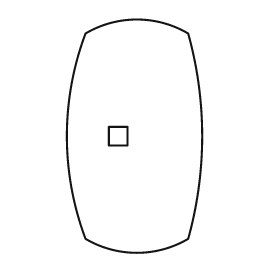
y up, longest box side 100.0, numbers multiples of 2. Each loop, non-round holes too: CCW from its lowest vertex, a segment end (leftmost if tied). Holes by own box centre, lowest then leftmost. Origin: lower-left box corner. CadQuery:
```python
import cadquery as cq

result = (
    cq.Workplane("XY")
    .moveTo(8.0, 6.0)
    .threePointArc((30.0, 0.0), (52.0, 6.0))
    .threePointArc((58.0, 50.0), (52.0, 94.0))
    .threePointArc((30.0, 100.0), (8.0, 94.0))
    .threePointArc((0.0, 50.0), (8.0, 6.0))
    .close()
    .moveTo(18.0, 46.0)
    .lineTo(26.0, 46.0)
    .lineTo(26.0, 54.0)
    .lineTo(18.0, 54.0)
    .close()
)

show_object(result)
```